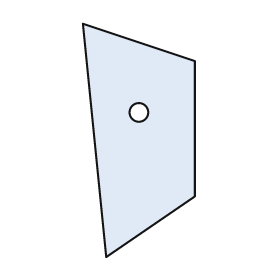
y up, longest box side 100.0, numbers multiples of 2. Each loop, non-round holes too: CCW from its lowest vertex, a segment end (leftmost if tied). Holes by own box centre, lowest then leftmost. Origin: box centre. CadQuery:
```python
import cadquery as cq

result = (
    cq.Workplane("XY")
    .moveTo(-14.0, -50.0)
    .lineTo(24.0, -24.0)
    .lineTo(24.0, 34.0)
    .lineTo(-24.0, 50.0)
    .close()
    .moveTo(0.0, 12.0)
    .circle(4.0)
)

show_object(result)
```